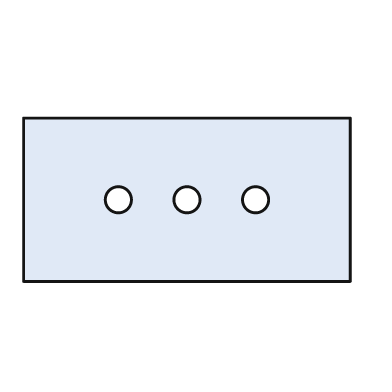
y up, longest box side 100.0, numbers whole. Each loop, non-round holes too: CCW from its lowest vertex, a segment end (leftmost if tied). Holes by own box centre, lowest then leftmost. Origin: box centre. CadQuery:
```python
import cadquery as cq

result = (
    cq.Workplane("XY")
    .moveTo(-50.0, -25.0)
    .lineTo(50.0, -25.0)
    .lineTo(50.0, 25.0)
    .lineTo(-50.0, 25.0)
    .close()
    .moveTo(-21.0, 0.0)
    .circle(4.0)
    .moveTo(0.0, 0.0)
    .circle(4.0)
    .moveTo(21.0, 0.0)
    .circle(4.0)
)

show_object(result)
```